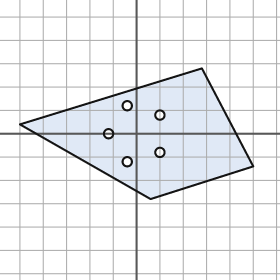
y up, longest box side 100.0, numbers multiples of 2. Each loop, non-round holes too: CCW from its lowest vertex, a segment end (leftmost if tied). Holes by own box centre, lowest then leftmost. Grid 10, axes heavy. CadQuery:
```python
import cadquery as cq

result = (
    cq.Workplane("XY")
    .moveTo(6.0, -28.0)
    .lineTo(50.0, -14.0)
    .lineTo(28.0, 28.0)
    .lineTo(-50.0, 4.0)
    .close()
    .moveTo(-4.0, -12.0)
    .circle(2.0)
    .moveTo(10.0, -8.0)
    .circle(2.0)
    .moveTo(-12.0, 0.0)
    .circle(2.0)
    .moveTo(10.0, 8.0)
    .circle(2.0)
    .moveTo(-4.0, 12.0)
    .circle(2.0)
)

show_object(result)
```